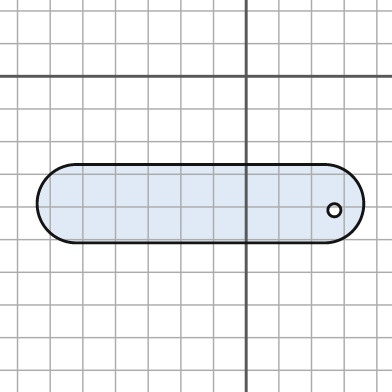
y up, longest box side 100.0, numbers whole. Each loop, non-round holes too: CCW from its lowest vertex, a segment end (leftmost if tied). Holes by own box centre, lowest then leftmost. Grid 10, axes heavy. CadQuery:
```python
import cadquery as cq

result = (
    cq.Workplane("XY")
    .moveTo(-52.0, -51.0)
    .lineTo(24.0, -51.0)
    .threePointArc((36.0, -39.0), (24.0, -27.0))
    .lineTo(-52.0, -27.0)
    .threePointArc((-64.0, -39.0), (-52.0, -51.0))
    .close()
    .moveTo(27.0, -41.0)
    .circle(2.0)
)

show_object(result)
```